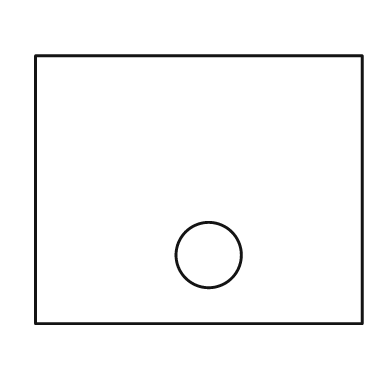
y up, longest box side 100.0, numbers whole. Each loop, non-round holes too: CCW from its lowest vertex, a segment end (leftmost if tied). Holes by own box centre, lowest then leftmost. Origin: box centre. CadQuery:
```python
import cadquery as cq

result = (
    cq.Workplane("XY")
    .moveTo(-50.0, -41.0)
    .lineTo(50.0, -41.0)
    .lineTo(50.0, 41.0)
    .lineTo(-50.0, 41.0)
    .close()
    .moveTo(3.0, -20.0)
    .circle(10.0)
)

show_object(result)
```